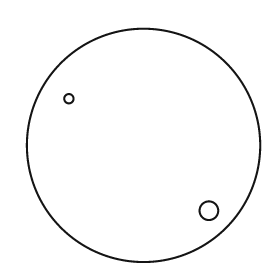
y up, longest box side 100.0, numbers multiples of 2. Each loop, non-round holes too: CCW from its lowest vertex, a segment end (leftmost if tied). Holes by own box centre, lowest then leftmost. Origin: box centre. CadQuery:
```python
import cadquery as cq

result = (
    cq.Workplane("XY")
    .moveTo(0.0, 0.0)
    .circle(50.0)
    .moveTo(28.0, -28.0)
    .circle(4.0)
    .moveTo(-32.0, 20.0)
    .circle(2.0)
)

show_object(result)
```